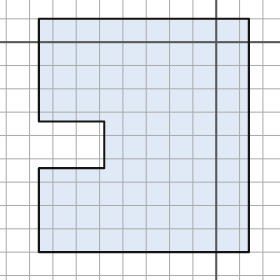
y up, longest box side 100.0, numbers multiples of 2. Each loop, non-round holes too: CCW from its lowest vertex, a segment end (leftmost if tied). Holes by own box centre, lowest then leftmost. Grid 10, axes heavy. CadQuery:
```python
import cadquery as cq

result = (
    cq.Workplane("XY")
    .moveTo(-76.0, -90.0)
    .lineTo(14.0, -90.0)
    .lineTo(14.0, 10.0)
    .lineTo(-76.0, 10.0)
    .lineTo(-76.0, -34.0)
    .lineTo(-48.0, -34.0)
    .lineTo(-48.0, -54.0)
    .lineTo(-76.0, -54.0)
    .close()
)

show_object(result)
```